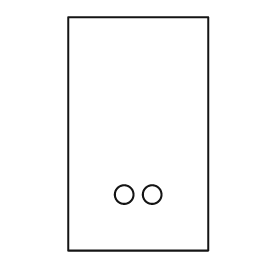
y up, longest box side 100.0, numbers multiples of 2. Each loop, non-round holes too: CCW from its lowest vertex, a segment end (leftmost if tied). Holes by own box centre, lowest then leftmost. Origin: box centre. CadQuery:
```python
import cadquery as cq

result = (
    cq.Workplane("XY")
    .moveTo(-30.0, -50.0)
    .lineTo(30.0, -50.0)
    .lineTo(30.0, 50.0)
    .lineTo(-30.0, 50.0)
    .close()
    .moveTo(-6.0, -26.0)
    .circle(4.0)
    .moveTo(6.0, -26.0)
    .circle(4.0)
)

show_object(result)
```